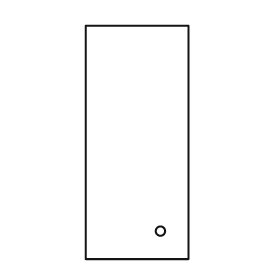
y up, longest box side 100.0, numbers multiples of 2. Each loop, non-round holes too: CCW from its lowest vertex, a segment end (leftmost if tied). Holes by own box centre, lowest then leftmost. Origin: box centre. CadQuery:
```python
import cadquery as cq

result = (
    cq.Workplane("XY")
    .moveTo(-22.0, -50.0)
    .lineTo(22.0, -50.0)
    .lineTo(22.0, 50.0)
    .lineTo(-22.0, 50.0)
    .close()
    .moveTo(10.0, -38.0)
    .circle(2.0)
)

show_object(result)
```